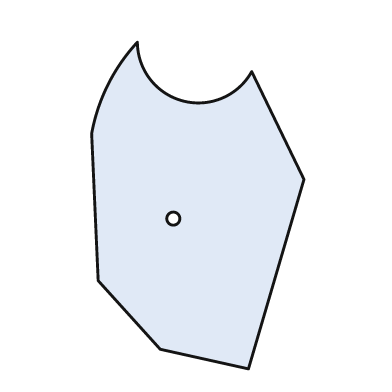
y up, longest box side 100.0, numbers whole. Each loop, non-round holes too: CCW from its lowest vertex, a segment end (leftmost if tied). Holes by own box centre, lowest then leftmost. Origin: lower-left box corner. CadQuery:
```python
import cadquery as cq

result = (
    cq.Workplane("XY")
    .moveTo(48.0, 0.0)
    .lineTo(65.0, 58.0)
    .lineTo(49.0, 91.0)
    .threePointArc((28.0, 82.0), (14.0, 100.0))
    .threePointArc((5.0, 87.0), (0.0, 72.0))
    .lineTo(2.0, 27.0)
    .lineTo(21.0, 6.0)
    .close()
    .moveTo(25.0, 46.0)
    .circle(2.0)
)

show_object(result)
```